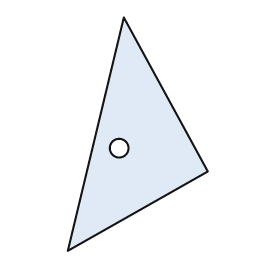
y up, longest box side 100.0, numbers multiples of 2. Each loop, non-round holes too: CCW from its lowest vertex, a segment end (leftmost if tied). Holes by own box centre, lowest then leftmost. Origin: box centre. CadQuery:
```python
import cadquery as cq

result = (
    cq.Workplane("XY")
    .moveTo(-30.0, -50.0)
    .lineTo(30.0, -16.0)
    .lineTo(-6.0, 50.0)
    .close()
    .moveTo(-8.0, -6.0)
    .circle(4.0)
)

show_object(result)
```